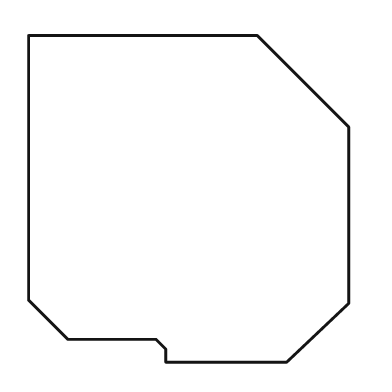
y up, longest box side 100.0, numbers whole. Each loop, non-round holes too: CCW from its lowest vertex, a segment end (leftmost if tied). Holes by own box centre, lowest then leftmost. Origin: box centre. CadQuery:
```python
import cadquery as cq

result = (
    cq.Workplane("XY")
    .moveTo(-7.0, -50.0)
    .lineTo(30.0, -50.0)
    .lineTo(49.0, -32.0)
    .lineTo(49.0, 22.0)
    .lineTo(21.0, 50.0)
    .lineTo(-49.0, 50.0)
    .lineTo(-49.0, -31.0)
    .lineTo(-37.0, -43.0)
    .lineTo(-10.0, -43.0)
    .lineTo(-7.0, -46.0)
    .close()
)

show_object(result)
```